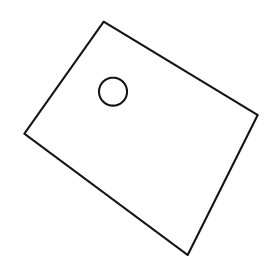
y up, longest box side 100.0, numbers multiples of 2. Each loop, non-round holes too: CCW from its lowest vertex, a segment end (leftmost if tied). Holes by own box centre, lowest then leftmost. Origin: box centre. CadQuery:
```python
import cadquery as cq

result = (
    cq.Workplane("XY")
    .moveTo(20.0, -50.0)
    .lineTo(50.0, 10.0)
    .lineTo(-16.0, 50.0)
    .lineTo(-50.0, 2.0)
    .close()
    .moveTo(-12.0, 20.0)
    .circle(6.0)
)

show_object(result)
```